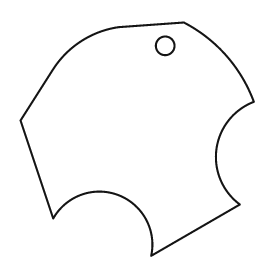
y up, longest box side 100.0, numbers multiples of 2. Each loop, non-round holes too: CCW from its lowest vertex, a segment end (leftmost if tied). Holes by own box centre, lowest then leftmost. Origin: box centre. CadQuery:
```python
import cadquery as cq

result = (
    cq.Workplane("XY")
    .moveTo(6.0, -50.0)
    .lineTo(44.0, -28.0)
    .threePointArc((34.0, -4.0), (50.0, 16.0))
    .threePointArc((38.0, 36.0), (20.0, 50.0))
    .lineTo(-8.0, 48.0)
    .threePointArc((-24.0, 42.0), (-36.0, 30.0))
    .lineTo(-50.0, 8.0)
    .lineTo(-36.0, -34.0)
    .threePointArc((-8.0, -24.0), (6.0, -50.0))
    .close()
    .moveTo(12.0, 40.0)
    .circle(4.0)
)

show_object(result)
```